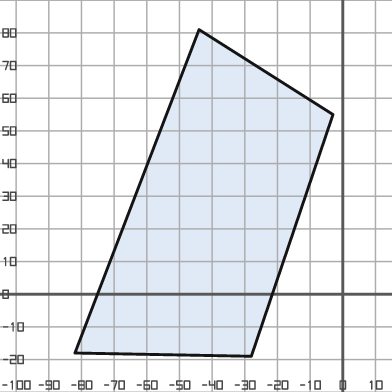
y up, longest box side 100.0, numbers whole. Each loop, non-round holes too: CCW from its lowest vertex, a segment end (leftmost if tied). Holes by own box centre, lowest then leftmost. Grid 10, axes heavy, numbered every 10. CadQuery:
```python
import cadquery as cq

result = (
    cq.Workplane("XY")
    .moveTo(-28.0, -19.0)
    .lineTo(-3.0, 55.0)
    .lineTo(-44.0, 81.0)
    .lineTo(-82.0, -18.0)
    .close()
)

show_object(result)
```